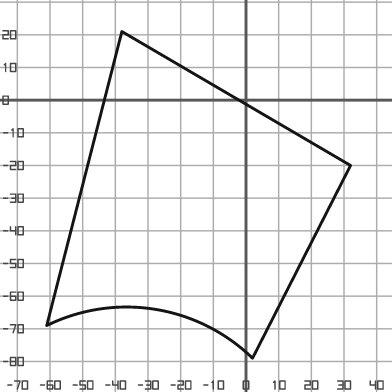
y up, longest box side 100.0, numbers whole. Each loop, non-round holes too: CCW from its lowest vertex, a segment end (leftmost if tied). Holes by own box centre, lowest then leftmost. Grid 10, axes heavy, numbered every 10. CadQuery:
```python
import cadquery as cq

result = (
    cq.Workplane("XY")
    .moveTo(2.0, -79.0)
    .lineTo(32.0, -20.0)
    .lineTo(-38.0, 21.0)
    .lineTo(-61.0, -69.0)
    .threePointArc((-28.0, -64.0), (2.0, -79.0))
    .close()
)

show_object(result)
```